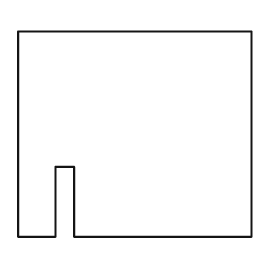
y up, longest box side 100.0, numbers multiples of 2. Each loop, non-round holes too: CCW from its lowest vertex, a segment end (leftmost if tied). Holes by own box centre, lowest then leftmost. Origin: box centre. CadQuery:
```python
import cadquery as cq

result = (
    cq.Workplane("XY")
    .moveTo(-50.0, -44.0)
    .lineTo(-34.0, -44.0)
    .lineTo(-34.0, -14.0)
    .lineTo(-26.0, -14.0)
    .lineTo(-26.0, -44.0)
    .lineTo(50.0, -44.0)
    .lineTo(50.0, 44.0)
    .lineTo(-50.0, 44.0)
    .close()
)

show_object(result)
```